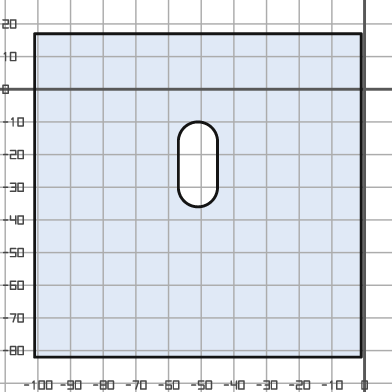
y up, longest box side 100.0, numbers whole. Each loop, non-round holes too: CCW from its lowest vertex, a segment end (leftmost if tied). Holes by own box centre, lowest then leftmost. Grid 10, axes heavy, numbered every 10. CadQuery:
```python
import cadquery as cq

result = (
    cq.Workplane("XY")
    .moveTo(-101.0, -82.0)
    .lineTo(-1.0, -82.0)
    .lineTo(-1.0, 17.0)
    .lineTo(-101.0, 17.0)
    .close()
    .moveTo(-57.0, -30.0)
    .threePointArc((-51.0, -36.0), (-45.0, -30.0))
    .lineTo(-45.0, -16.0)
    .threePointArc((-51.0, -10.0), (-57.0, -16.0))
    .close()
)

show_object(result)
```